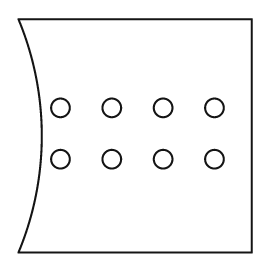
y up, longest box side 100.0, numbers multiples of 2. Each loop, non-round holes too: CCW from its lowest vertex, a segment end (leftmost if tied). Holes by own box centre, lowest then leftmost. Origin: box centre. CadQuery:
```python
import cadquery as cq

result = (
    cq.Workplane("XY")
    .moveTo(-50.0, -50.0)
    .lineTo(50.0, -50.0)
    .lineTo(50.0, 50.0)
    .lineTo(-50.0, 50.0)
    .threePointArc((-40.0, 0.0), (-50.0, -50.0))
    .close()
    .moveTo(-32.0, -10.0)
    .circle(4.0)
    .moveTo(-10.0, -10.0)
    .circle(4.0)
    .moveTo(12.0, -10.0)
    .circle(4.0)
    .moveTo(34.0, -10.0)
    .circle(4.0)
    .moveTo(-32.0, 12.0)
    .circle(4.0)
    .moveTo(-10.0, 12.0)
    .circle(4.0)
    .moveTo(12.0, 12.0)
    .circle(4.0)
    .moveTo(34.0, 12.0)
    .circle(4.0)
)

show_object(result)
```